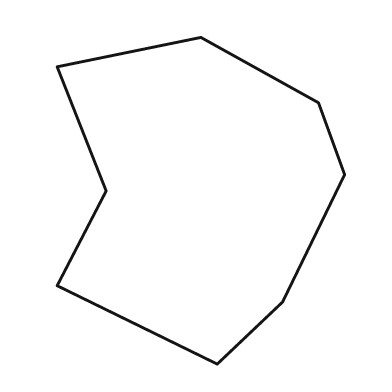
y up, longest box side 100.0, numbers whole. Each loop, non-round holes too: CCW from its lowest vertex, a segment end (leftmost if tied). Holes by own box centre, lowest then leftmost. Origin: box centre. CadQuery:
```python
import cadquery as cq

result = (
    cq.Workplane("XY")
    .moveTo(5.0, -50.0)
    .lineTo(25.0, -31.0)
    .lineTo(44.0, 8.0)
    .lineTo(36.0, 30.0)
    .lineTo(0.0, 50.0)
    .lineTo(-44.0, 41.0)
    .lineTo(-29.0, 3.0)
    .lineTo(-44.0, -26.0)
    .close()
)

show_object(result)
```